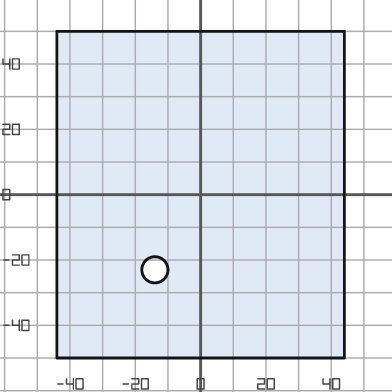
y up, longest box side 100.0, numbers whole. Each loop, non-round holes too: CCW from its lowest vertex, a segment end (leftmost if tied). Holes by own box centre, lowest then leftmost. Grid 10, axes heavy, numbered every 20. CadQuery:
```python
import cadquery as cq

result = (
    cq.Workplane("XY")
    .moveTo(-44.0, -50.0)
    .lineTo(44.0, -50.0)
    .lineTo(44.0, 50.0)
    .lineTo(-44.0, 50.0)
    .close()
    .moveTo(-14.0, -23.0)
    .circle(4.0)
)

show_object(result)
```